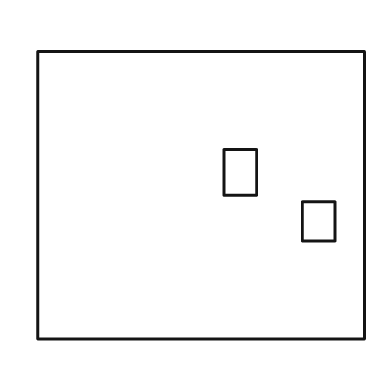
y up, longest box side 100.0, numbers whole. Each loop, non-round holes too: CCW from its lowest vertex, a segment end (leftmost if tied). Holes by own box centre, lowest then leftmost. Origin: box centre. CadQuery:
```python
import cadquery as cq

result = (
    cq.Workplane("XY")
    .moveTo(-50.0, -44.0)
    .lineTo(50.0, -44.0)
    .lineTo(50.0, 44.0)
    .lineTo(-50.0, 44.0)
    .close()
    .moveTo(31.0, -14.0)
    .lineTo(41.0, -14.0)
    .lineTo(41.0, -2.0)
    .lineTo(31.0, -2.0)
    .close()
    .moveTo(7.0, 0.0)
    .lineTo(17.0, 0.0)
    .lineTo(17.0, 14.0)
    .lineTo(7.0, 14.0)
    .close()
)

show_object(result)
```